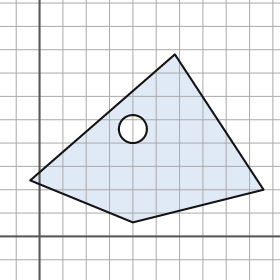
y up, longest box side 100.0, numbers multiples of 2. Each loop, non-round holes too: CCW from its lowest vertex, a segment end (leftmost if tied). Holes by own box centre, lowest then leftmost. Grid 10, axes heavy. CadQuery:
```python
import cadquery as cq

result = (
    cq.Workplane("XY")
    .moveTo(40.0, 6.0)
    .lineTo(96.0, 20.0)
    .lineTo(58.0, 78.0)
    .lineTo(-4.0, 24.0)
    .close()
    .moveTo(40.0, 46.0)
    .circle(6.0)
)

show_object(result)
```